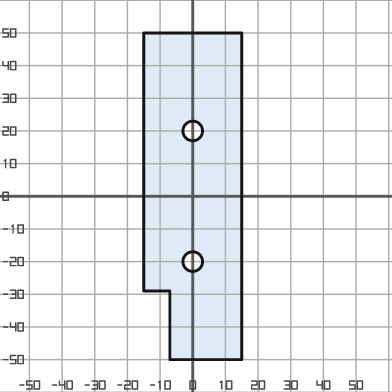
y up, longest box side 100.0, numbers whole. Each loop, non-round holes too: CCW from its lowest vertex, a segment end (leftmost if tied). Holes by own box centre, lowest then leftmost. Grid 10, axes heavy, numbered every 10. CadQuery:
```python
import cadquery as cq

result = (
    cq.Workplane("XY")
    .moveTo(-7.0, -50.0)
    .lineTo(15.0, -50.0)
    .lineTo(15.0, 50.0)
    .lineTo(-15.0, 50.0)
    .lineTo(-15.0, -29.0)
    .lineTo(-7.0, -29.0)
    .close()
    .moveTo(0.0, -20.0)
    .circle(3.0)
    .moveTo(0.0, 20.0)
    .circle(3.0)
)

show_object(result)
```